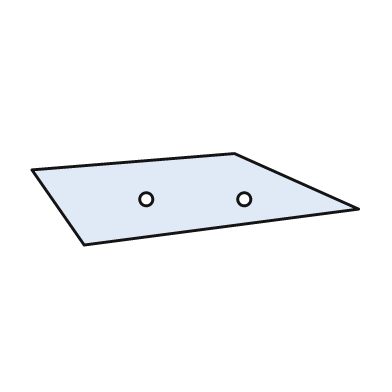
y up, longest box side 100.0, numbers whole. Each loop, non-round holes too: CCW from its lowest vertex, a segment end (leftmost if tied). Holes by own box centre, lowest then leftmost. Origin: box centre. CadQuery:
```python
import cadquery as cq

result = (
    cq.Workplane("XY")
    .moveTo(-34.0, -14.0)
    .lineTo(50.0, -3.0)
    .lineTo(12.0, 14.0)
    .lineTo(-50.0, 9.0)
    .close()
    .moveTo(-15.0, 0.0)
    .circle(2.0)
    .moveTo(15.0, 0.0)
    .circle(2.0)
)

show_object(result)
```